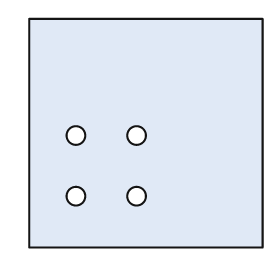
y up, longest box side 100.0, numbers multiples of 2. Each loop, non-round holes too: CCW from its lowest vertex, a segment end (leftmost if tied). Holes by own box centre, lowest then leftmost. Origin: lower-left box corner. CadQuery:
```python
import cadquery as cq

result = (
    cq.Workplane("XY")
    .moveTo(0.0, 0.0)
    .lineTo(100.0, 0.0)
    .lineTo(100.0, 98.0)
    .lineTo(0.0, 98.0)
    .close()
    .moveTo(20.0, 22.0)
    .circle(4.0)
    .moveTo(46.0, 22.0)
    .circle(4.0)
    .moveTo(20.0, 48.0)
    .circle(4.0)
    .moveTo(46.0, 48.0)
    .circle(4.0)
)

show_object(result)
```